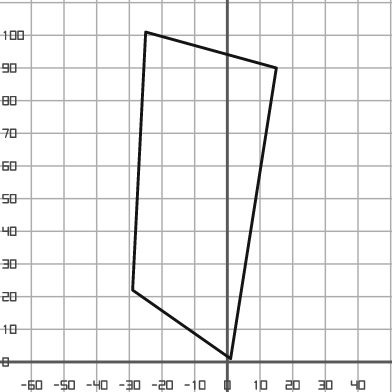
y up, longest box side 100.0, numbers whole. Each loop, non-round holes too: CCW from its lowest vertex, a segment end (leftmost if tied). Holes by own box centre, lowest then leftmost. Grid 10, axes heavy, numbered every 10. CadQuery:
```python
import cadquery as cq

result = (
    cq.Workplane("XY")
    .moveTo(1.0, 1.0)
    .lineTo(15.0, 90.0)
    .lineTo(-25.0, 101.0)
    .lineTo(-29.0, 22.0)
    .close()
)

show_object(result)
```